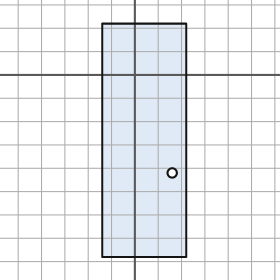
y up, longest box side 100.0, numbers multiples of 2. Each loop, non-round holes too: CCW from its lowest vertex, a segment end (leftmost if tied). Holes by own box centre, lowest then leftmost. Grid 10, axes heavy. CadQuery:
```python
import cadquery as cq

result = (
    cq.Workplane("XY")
    .moveTo(-14.0, -78.0)
    .lineTo(22.0, -78.0)
    .lineTo(22.0, 22.0)
    .lineTo(-14.0, 22.0)
    .close()
    .moveTo(16.0, -42.0)
    .circle(2.0)
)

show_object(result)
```